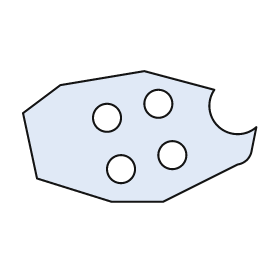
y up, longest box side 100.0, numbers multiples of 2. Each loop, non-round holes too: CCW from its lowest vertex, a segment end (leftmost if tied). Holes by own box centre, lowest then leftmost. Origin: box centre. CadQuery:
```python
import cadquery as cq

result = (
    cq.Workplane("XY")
    .moveTo(-12.0, -28.0)
    .lineTo(10.0, -28.0)
    .lineTo(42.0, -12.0)
    .threePointArc((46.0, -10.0), (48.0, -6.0))
    .lineTo(50.0, 4.0)
    .threePointArc((34.0, 4.0), (32.0, 20.0))
    .lineTo(2.0, 28.0)
    .lineTo(-34.0, 22.0)
    .lineTo(-50.0, 10.0)
    .lineTo(-44.0, -18.0)
    .close()
    .moveTo(-8.0, -14.0)
    .circle(6.0)
    .moveTo(14.0, -8.0)
    .circle(6.0)
    .moveTo(-14.0, 8.0)
    .circle(6.0)
    .moveTo(8.0, 14.0)
    .circle(6.0)
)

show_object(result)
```